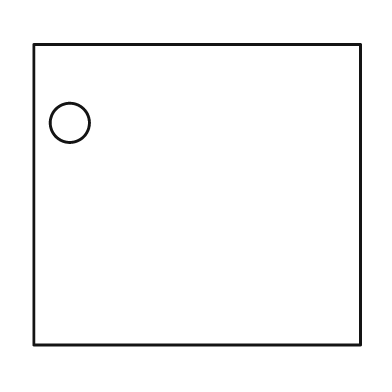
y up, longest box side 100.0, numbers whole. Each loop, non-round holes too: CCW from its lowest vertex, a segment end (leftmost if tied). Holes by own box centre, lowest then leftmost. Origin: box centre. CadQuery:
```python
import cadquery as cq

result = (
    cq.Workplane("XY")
    .moveTo(-50.0, -46.0)
    .lineTo(50.0, -46.0)
    .lineTo(50.0, 46.0)
    .lineTo(-50.0, 46.0)
    .close()
    .moveTo(-39.0, 22.0)
    .circle(6.0)
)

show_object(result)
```